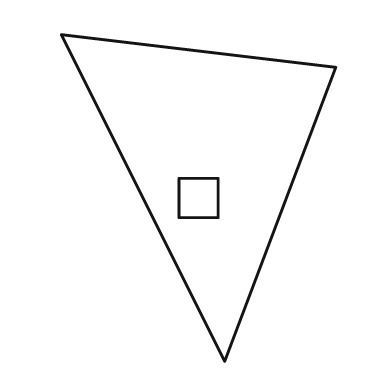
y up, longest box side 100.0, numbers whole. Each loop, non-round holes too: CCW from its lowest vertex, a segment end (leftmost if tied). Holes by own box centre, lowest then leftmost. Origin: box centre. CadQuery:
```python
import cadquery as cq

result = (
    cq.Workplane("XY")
    .moveTo(8.0, -50.0)
    .lineTo(42.0, 40.0)
    .lineTo(-42.0, 50.0)
    .close()
    .moveTo(-6.0, -6.0)
    .lineTo(6.0, -6.0)
    .lineTo(6.0, 6.0)
    .lineTo(-6.0, 6.0)
    .close()
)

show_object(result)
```